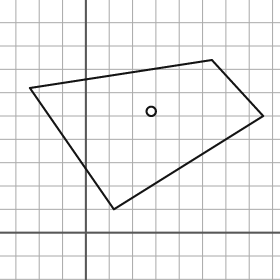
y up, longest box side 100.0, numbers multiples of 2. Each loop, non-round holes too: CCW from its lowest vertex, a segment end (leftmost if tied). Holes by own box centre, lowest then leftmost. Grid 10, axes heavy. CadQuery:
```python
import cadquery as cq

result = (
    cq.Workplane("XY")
    .moveTo(12.0, 10.0)
    .lineTo(76.0, 50.0)
    .lineTo(54.0, 74.0)
    .lineTo(-24.0, 62.0)
    .close()
    .moveTo(28.0, 52.0)
    .circle(2.0)
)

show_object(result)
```